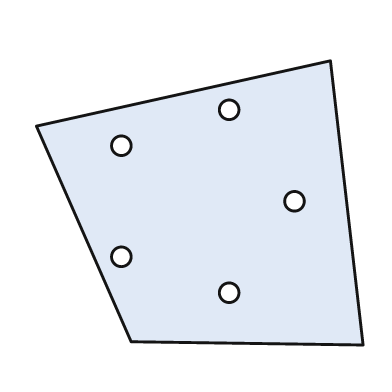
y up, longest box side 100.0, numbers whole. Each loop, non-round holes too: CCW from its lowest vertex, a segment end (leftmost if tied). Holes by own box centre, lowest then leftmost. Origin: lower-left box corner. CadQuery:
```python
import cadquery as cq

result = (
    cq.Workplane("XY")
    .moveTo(100.0, 0.0)
    .lineTo(90.0, 87.0)
    .lineTo(0.0, 67.0)
    .lineTo(29.0, 1.0)
    .close()
    .moveTo(59.0, 16.0)
    .circle(3.0)
    .moveTo(26.0, 27.0)
    .circle(3.0)
    .moveTo(79.0, 44.0)
    .circle(3.0)
    .moveTo(26.0, 61.0)
    .circle(3.0)
    .moveTo(59.0, 72.0)
    .circle(3.0)
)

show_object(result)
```